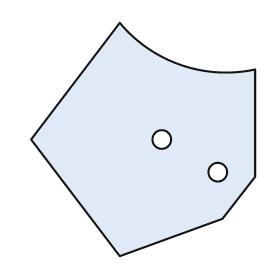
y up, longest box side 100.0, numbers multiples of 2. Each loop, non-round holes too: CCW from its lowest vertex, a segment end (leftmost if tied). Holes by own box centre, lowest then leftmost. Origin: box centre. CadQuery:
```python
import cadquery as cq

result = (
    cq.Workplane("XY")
    .moveTo(-10.0, -50.0)
    .lineTo(34.0, -34.0)
    .lineTo(48.0, -16.0)
    .lineTo(48.0, 30.0)
    .threePointArc((16.0, 32.0), (-10.0, 50.0))
    .lineTo(-48.0, 0.0)
    .close()
    .moveTo(32.0, -14.0)
    .circle(4.0)
    .moveTo(8.0, 0.0)
    .circle(4.0)
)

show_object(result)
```